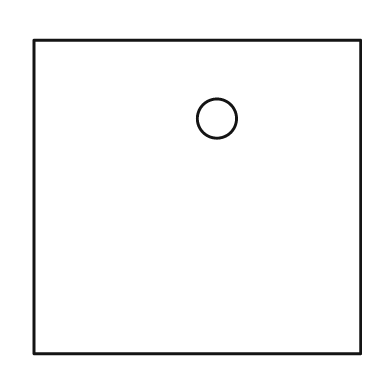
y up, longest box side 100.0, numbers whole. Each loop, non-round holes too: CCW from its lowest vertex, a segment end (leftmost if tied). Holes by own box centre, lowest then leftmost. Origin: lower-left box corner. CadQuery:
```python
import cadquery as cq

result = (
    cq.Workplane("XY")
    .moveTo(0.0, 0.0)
    .lineTo(100.0, 0.0)
    .lineTo(100.0, 96.0)
    .lineTo(0.0, 96.0)
    .close()
    .moveTo(56.0, 72.0)
    .circle(6.0)
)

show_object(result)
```